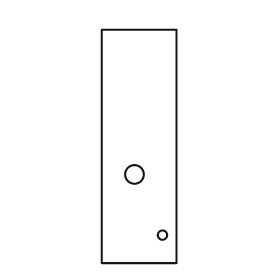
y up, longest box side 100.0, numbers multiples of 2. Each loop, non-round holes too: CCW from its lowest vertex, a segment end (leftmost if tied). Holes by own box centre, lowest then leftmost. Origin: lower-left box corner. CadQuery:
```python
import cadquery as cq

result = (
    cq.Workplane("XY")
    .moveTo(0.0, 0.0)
    .lineTo(32.0, 0.0)
    .lineTo(32.0, 100.0)
    .lineTo(0.0, 100.0)
    .close()
    .moveTo(26.0, 12.0)
    .circle(2.0)
    .moveTo(14.0, 38.0)
    .circle(4.0)
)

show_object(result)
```